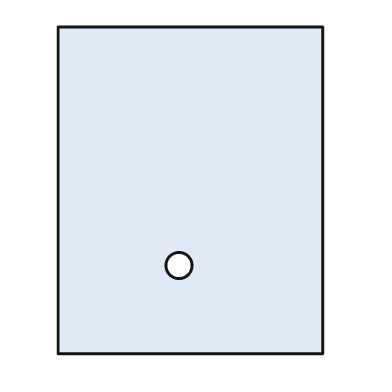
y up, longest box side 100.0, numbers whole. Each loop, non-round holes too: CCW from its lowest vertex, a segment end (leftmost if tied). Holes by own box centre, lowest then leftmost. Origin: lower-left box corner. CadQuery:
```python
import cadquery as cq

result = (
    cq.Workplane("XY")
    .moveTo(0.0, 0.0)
    .lineTo(81.0, 0.0)
    .lineTo(81.0, 100.0)
    .lineTo(0.0, 100.0)
    .close()
    .moveTo(37.0, 27.0)
    .circle(4.0)
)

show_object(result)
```